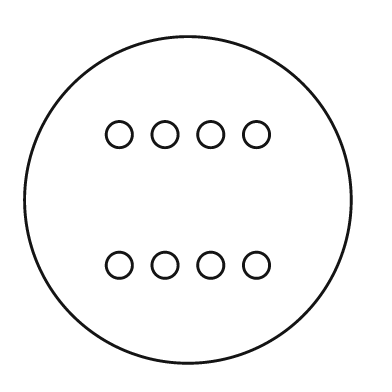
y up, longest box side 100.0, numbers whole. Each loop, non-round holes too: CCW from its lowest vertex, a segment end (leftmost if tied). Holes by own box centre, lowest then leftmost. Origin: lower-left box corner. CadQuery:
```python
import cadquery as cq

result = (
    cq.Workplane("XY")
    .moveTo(50.0, 50.0)
    .circle(50.0)
    .moveTo(29.0, 30.0)
    .circle(4.0)
    .moveTo(43.0, 30.0)
    .circle(4.0)
    .moveTo(57.0, 30.0)
    .circle(4.0)
    .moveTo(71.0, 30.0)
    .circle(4.0)
    .moveTo(29.0, 70.0)
    .circle(4.0)
    .moveTo(43.0, 70.0)
    .circle(4.0)
    .moveTo(57.0, 70.0)
    .circle(4.0)
    .moveTo(71.0, 70.0)
    .circle(4.0)
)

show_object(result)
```